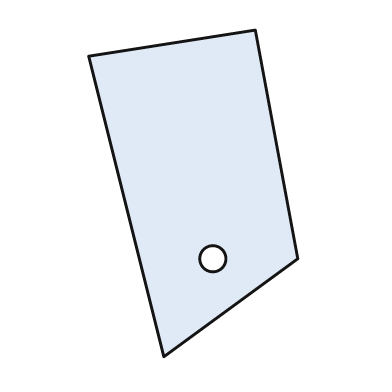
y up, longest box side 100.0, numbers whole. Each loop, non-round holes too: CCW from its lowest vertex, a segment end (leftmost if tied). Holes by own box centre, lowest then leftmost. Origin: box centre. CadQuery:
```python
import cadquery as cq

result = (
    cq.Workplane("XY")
    .moveTo(-9.0, -50.0)
    .lineTo(32.0, -20.0)
    .lineTo(19.0, 50.0)
    .lineTo(-32.0, 42.0)
    .close()
    .moveTo(6.0, -20.0)
    .circle(4.0)
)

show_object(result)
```